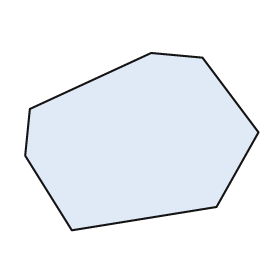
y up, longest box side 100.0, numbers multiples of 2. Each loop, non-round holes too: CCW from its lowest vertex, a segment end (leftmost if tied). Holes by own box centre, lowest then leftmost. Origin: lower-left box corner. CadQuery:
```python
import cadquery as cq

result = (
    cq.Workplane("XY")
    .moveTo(20.0, 0.0)
    .lineTo(82.0, 10.0)
    .lineTo(100.0, 42.0)
    .lineTo(76.0, 74.0)
    .lineTo(54.0, 76.0)
    .lineTo(2.0, 52.0)
    .lineTo(0.0, 32.0)
    .close()
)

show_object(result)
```